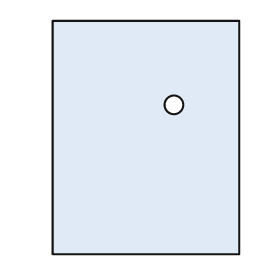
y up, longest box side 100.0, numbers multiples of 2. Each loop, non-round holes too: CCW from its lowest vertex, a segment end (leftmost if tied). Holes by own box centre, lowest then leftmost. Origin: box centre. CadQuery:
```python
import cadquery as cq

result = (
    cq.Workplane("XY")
    .moveTo(-40.0, -50.0)
    .lineTo(40.0, -50.0)
    .lineTo(40.0, 50.0)
    .lineTo(-40.0, 50.0)
    .close()
    .moveTo(12.0, 14.0)
    .circle(4.0)
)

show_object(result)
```